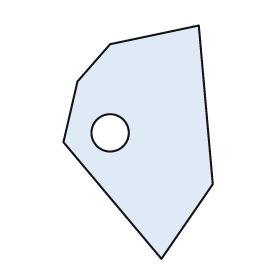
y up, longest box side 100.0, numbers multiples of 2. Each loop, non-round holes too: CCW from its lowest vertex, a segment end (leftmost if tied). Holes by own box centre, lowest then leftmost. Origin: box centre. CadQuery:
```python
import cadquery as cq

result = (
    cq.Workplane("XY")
    .moveTo(10.0, -50.0)
    .lineTo(32.0, -18.0)
    .lineTo(26.0, 50.0)
    .lineTo(-12.0, 42.0)
    .lineTo(-26.0, 26.0)
    .lineTo(-32.0, 0.0)
    .close()
    .moveTo(-12.0, 4.0)
    .circle(8.0)
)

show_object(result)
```